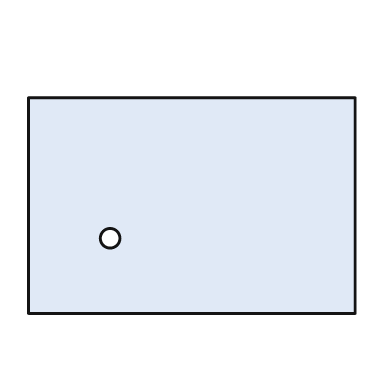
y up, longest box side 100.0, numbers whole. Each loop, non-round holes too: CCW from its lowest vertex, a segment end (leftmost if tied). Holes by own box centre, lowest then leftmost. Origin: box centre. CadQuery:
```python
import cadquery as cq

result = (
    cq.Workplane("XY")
    .moveTo(-50.0, -33.0)
    .lineTo(50.0, -33.0)
    .lineTo(50.0, 33.0)
    .lineTo(-50.0, 33.0)
    .close()
    .moveTo(-25.0, -10.0)
    .circle(3.0)
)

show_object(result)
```